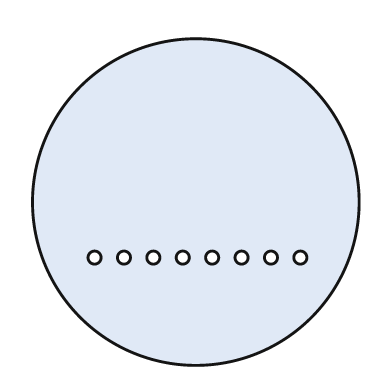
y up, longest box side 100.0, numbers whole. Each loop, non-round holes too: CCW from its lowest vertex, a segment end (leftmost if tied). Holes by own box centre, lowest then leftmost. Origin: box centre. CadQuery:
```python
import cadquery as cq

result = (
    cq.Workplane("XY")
    .moveTo(0.0, 0.0)
    .circle(50.0)
    .moveTo(-31.0, -17.0)
    .circle(2.0)
    .moveTo(-22.0, -17.0)
    .circle(2.0)
    .moveTo(-13.0, -17.0)
    .circle(2.0)
    .moveTo(-4.0, -17.0)
    .circle(2.0)
    .moveTo(5.0, -17.0)
    .circle(2.0)
    .moveTo(14.0, -17.0)
    .circle(2.0)
    .moveTo(23.0, -17.0)
    .circle(2.0)
    .moveTo(32.0, -17.0)
    .circle(2.0)
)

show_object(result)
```